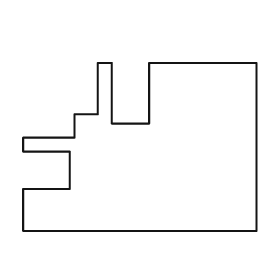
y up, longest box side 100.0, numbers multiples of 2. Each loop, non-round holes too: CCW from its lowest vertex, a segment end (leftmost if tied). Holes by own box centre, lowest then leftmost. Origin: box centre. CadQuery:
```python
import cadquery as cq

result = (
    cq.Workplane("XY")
    .moveTo(-50.0, -36.0)
    .lineTo(50.0, -36.0)
    .lineTo(50.0, 36.0)
    .lineTo(4.0, 36.0)
    .lineTo(4.0, 10.0)
    .lineTo(-12.0, 10.0)
    .lineTo(-12.0, 36.0)
    .lineTo(-18.0, 36.0)
    .lineTo(-18.0, 14.0)
    .lineTo(-28.0, 14.0)
    .lineTo(-28.0, 4.0)
    .lineTo(-50.0, 4.0)
    .lineTo(-50.0, -2.0)
    .lineTo(-30.0, -2.0)
    .lineTo(-30.0, -18.0)
    .lineTo(-50.0, -18.0)
    .close()
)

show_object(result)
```